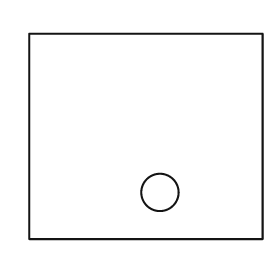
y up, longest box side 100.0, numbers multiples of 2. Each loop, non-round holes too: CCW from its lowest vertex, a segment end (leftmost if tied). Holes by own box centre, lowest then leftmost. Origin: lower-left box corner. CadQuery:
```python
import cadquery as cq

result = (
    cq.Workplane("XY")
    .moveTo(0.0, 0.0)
    .lineTo(100.0, 0.0)
    .lineTo(100.0, 88.0)
    .lineTo(0.0, 88.0)
    .close()
    .moveTo(56.0, 20.0)
    .circle(8.0)
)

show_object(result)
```